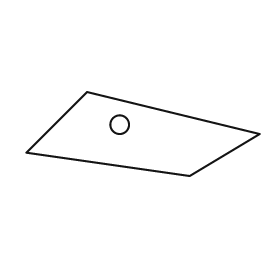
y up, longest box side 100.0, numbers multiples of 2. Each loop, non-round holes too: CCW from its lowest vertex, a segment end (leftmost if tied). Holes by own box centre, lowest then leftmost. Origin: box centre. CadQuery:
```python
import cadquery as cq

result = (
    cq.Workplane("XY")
    .moveTo(20.0, -18.0)
    .lineTo(50.0, 0.0)
    .lineTo(-24.0, 18.0)
    .lineTo(-50.0, -8.0)
    .close()
    .moveTo(-10.0, 4.0)
    .circle(4.0)
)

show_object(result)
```